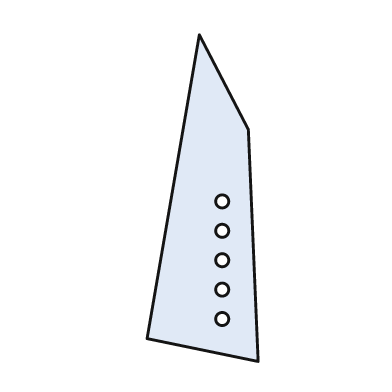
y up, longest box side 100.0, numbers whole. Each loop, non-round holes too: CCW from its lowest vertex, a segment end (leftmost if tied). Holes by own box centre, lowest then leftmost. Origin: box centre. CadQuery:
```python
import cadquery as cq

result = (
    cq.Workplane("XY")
    .moveTo(17.0, -50.0)
    .lineTo(14.0, 21.0)
    .lineTo(-1.0, 50.0)
    .lineTo(-17.0, -43.0)
    .close()
    .moveTo(6.0, -37.0)
    .circle(2.0)
    .moveTo(6.0, -28.0)
    .circle(2.0)
    .moveTo(6.0, -19.0)
    .circle(2.0)
    .moveTo(6.0, -10.0)
    .circle(2.0)
    .moveTo(6.0, -1.0)
    .circle(2.0)
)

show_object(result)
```